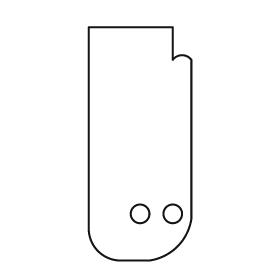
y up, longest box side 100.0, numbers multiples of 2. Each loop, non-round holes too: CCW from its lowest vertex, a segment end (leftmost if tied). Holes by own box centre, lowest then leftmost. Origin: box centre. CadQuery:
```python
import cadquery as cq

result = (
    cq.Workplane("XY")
    .moveTo(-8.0, -50.0)
    .lineTo(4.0, -50.0)
    .threePointArc((16.0, -44.0), (22.0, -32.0))
    .lineTo(22.0, 36.0)
    .threePointArc((18.0, 38.0), (14.0, 36.0))
    .lineTo(14.0, 50.0)
    .lineTo(-22.0, 50.0)
    .lineTo(-22.0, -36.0)
    .threePointArc((-18.0, -46.0), (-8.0, -50.0))
    .close()
    .moveTo(0.0, -30.0)
    .circle(4.0)
    .moveTo(14.0, -30.0)
    .circle(4.0)
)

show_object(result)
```